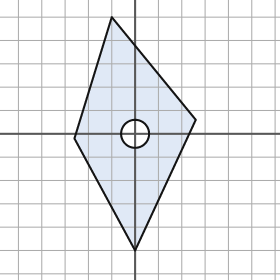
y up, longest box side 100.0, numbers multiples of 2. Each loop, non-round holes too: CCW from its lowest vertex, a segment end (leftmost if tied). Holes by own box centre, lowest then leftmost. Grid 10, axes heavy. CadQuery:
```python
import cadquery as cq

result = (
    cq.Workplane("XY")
    .moveTo(0.0, -50.0)
    .lineTo(26.0, 6.0)
    .lineTo(-10.0, 50.0)
    .lineTo(-26.0, -2.0)
    .close()
    .moveTo(0.0, 0.0)
    .circle(6.0)
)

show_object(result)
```